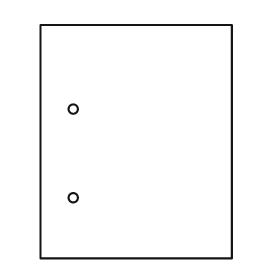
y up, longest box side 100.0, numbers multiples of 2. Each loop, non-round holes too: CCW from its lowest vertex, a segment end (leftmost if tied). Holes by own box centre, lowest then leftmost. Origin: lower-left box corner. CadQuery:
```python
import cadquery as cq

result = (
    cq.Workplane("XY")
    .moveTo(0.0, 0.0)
    .lineTo(82.0, 0.0)
    .lineTo(82.0, 100.0)
    .lineTo(0.0, 100.0)
    .close()
    .moveTo(14.0, 26.0)
    .circle(2.0)
    .moveTo(14.0, 64.0)
    .circle(2.0)
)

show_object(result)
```